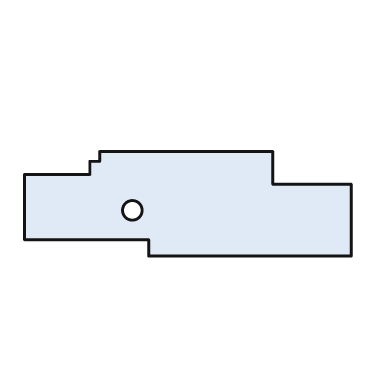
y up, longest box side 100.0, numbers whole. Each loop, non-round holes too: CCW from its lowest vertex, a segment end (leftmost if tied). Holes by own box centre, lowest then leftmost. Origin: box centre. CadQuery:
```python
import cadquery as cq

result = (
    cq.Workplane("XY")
    .moveTo(-12.0, -16.0)
    .lineTo(50.0, -16.0)
    .lineTo(50.0, 6.0)
    .lineTo(26.0, 6.0)
    .lineTo(26.0, 16.0)
    .lineTo(-27.0, 16.0)
    .lineTo(-27.0, 13.0)
    .lineTo(-30.0, 13.0)
    .lineTo(-30.0, 9.0)
    .lineTo(-50.0, 9.0)
    .lineTo(-50.0, -11.0)
    .lineTo(-12.0, -11.0)
    .close()
    .moveTo(-17.0, -2.0)
    .circle(3.0)
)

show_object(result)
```